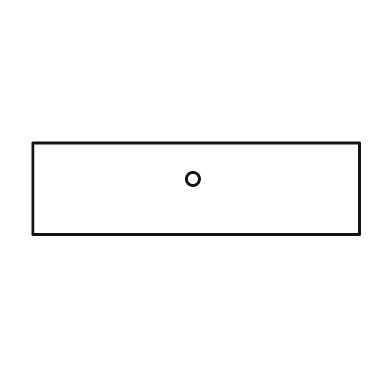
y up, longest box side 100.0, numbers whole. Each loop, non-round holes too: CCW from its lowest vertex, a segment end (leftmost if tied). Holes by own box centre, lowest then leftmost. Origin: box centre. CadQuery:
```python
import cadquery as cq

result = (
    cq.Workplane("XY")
    .moveTo(-50.0, -14.0)
    .lineTo(50.0, -14.0)
    .lineTo(50.0, 14.0)
    .lineTo(-50.0, 14.0)
    .close()
    .moveTo(-1.0, 3.0)
    .circle(2.0)
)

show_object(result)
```